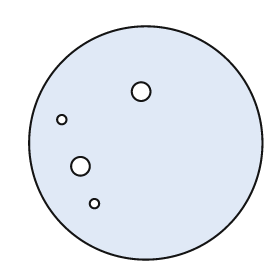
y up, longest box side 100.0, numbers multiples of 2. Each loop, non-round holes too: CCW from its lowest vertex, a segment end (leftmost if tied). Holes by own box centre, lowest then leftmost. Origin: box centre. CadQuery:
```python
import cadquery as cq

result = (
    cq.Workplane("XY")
    .moveTo(0.0, 0.0)
    .circle(50.0)
    .moveTo(-22.0, -26.0)
    .circle(2.0)
    .moveTo(-28.0, -10.0)
    .circle(4.0)
    .moveTo(-36.0, 10.0)
    .circle(2.0)
    .moveTo(-2.0, 22.0)
    .circle(4.0)
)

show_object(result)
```